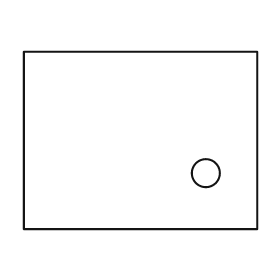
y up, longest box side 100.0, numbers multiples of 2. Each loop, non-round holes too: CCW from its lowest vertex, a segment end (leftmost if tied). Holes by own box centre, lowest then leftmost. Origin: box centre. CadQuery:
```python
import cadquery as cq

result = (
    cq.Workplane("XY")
    .moveTo(-50.0, -38.0)
    .lineTo(50.0, -38.0)
    .lineTo(50.0, 38.0)
    .lineTo(-50.0, 38.0)
    .close()
    .moveTo(28.0, -14.0)
    .circle(6.0)
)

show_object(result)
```